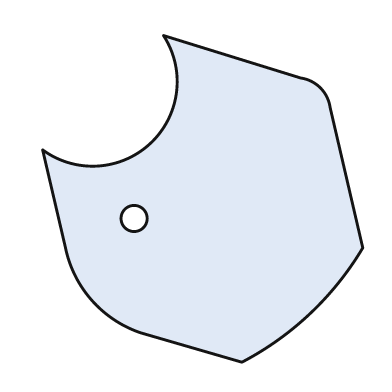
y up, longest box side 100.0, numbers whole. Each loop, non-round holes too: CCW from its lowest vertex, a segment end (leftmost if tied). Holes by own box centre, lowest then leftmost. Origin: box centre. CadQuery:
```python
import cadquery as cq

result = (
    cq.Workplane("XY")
    .moveTo(12.0, -50.0)
    .threePointArc((33.0, -35.0), (49.0, -15.0))
    .lineTo(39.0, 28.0)
    .threePointArc((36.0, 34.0), (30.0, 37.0))
    .lineTo(-12.0, 50.0)
    .threePointArc((-16.0, 17.0), (-49.0, 15.0))
    .lineTo(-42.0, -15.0)
    .threePointArc((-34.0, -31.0), (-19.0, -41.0))
    .close()
    .moveTo(-21.0, -6.0)
    .circle(4.0)
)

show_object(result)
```